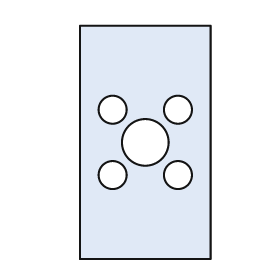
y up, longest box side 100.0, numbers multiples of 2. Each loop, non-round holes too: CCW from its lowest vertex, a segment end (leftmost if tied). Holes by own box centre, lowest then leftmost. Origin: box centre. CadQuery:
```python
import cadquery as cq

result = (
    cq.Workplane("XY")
    .moveTo(-28.0, -50.0)
    .lineTo(28.0, -50.0)
    .lineTo(28.0, 50.0)
    .lineTo(-28.0, 50.0)
    .close()
    .moveTo(-14.0, -14.0)
    .circle(6.0)
    .moveTo(14.0, -14.0)
    .circle(6.0)
    .moveTo(0.0, 0.0)
    .circle(10.0)
    .moveTo(-14.0, 14.0)
    .circle(6.0)
    .moveTo(14.0, 14.0)
    .circle(6.0)
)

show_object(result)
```